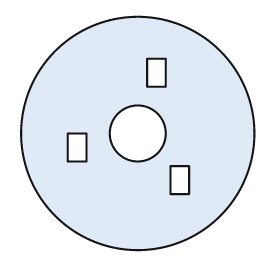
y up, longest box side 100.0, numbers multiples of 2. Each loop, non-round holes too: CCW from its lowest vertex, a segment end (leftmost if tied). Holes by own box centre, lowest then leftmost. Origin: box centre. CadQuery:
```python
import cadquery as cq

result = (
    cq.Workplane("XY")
    .moveTo(0.0, 0.0)
    .circle(50.0)
    .moveTo(14.0, -26.0)
    .lineTo(22.0, -26.0)
    .lineTo(22.0, -14.0)
    .lineTo(14.0, -14.0)
    .close()
    .moveTo(-30.0, -12.0)
    .lineTo(-22.0, -12.0)
    .lineTo(-22.0, 0.0)
    .lineTo(-30.0, 0.0)
    .close()
    .moveTo(0.0, 0.0)
    .circle(12.0)
    .moveTo(4.0, 20.0)
    .lineTo(12.0, 20.0)
    .lineTo(12.0, 32.0)
    .lineTo(4.0, 32.0)
    .close()
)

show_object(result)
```